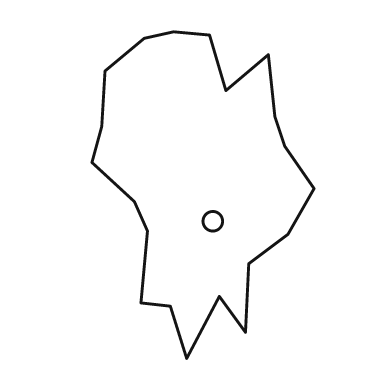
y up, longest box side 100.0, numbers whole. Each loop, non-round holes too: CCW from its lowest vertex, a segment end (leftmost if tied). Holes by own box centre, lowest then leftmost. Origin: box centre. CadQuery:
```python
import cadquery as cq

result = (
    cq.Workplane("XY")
    .moveTo(-5.0, -50.0)
    .lineTo(5.0, -31.0)
    .lineTo(13.0, -42.0)
    .lineTo(14.0, -21.0)
    .lineTo(26.0, -12.0)
    .lineTo(34.0, 2.0)
    .lineTo(25.0, 15.0)
    .lineTo(22.0, 24.0)
    .lineTo(20.0, 43.0)
    .lineTo(7.0, 32.0)
    .lineTo(2.0, 49.0)
    .lineTo(-9.0, 50.0)
    .lineTo(-18.0, 48.0)
    .lineTo(-30.0, 38.0)
    .lineTo(-31.0, 21.0)
    .lineTo(-34.0, 10.0)
    .lineTo(-21.0, -2.0)
    .lineTo(-17.0, -11.0)
    .lineTo(-19.0, -33.0)
    .lineTo(-10.0, -34.0)
    .close()
    .moveTo(3.0, -8.0)
    .circle(3.0)
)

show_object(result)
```